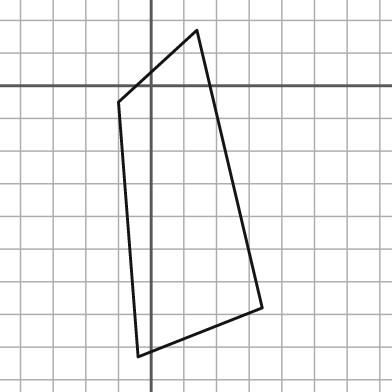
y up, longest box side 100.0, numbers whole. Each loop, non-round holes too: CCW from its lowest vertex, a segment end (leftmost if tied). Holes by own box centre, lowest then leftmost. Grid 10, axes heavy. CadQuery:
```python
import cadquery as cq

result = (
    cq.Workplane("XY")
    .moveTo(-4.0, -83.0)
    .lineTo(34.0, -68.0)
    .lineTo(14.0, 17.0)
    .lineTo(-10.0, -5.0)
    .close()
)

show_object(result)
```